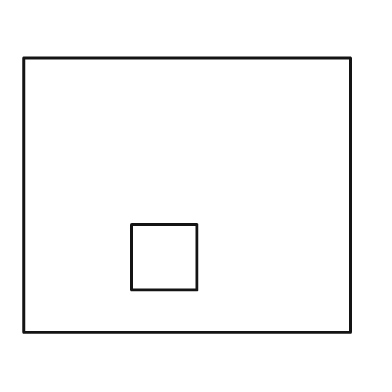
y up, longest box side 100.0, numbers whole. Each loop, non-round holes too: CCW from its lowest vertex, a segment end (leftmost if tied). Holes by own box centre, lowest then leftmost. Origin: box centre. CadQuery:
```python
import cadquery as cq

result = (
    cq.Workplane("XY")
    .moveTo(-50.0, -42.0)
    .lineTo(50.0, -42.0)
    .lineTo(50.0, 42.0)
    .lineTo(-50.0, 42.0)
    .close()
    .moveTo(-17.0, -29.0)
    .lineTo(3.0, -29.0)
    .lineTo(3.0, -9.0)
    .lineTo(-17.0, -9.0)
    .close()
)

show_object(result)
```